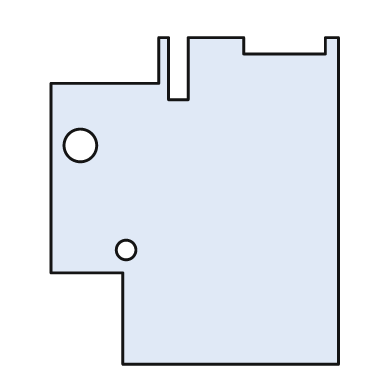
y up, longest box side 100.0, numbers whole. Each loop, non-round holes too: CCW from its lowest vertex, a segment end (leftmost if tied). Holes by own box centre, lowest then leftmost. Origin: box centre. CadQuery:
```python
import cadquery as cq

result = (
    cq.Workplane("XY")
    .moveTo(-22.0, -50.0)
    .lineTo(44.0, -50.0)
    .lineTo(44.0, 50.0)
    .lineTo(40.0, 50.0)
    .lineTo(40.0, 45.0)
    .lineTo(15.0, 45.0)
    .lineTo(15.0, 50.0)
    .lineTo(-2.0, 50.0)
    .lineTo(-2.0, 31.0)
    .lineTo(-8.0, 31.0)
    .lineTo(-8.0, 50.0)
    .lineTo(-11.0, 50.0)
    .lineTo(-11.0, 36.0)
    .lineTo(-44.0, 36.0)
    .lineTo(-44.0, -22.0)
    .lineTo(-22.0, -22.0)
    .close()
    .moveTo(-21.0, -15.0)
    .circle(3.0)
    .moveTo(-35.0, 17.0)
    .circle(5.0)
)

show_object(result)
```